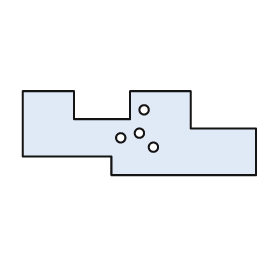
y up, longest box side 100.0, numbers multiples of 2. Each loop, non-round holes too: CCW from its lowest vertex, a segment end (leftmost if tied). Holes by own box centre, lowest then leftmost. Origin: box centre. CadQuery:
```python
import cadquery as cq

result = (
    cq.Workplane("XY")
    .moveTo(-12.0, -18.0)
    .lineTo(50.0, -18.0)
    .lineTo(50.0, 2.0)
    .lineTo(22.0, 2.0)
    .lineTo(22.0, 18.0)
    .lineTo(-4.0, 18.0)
    .lineTo(-4.0, 6.0)
    .lineTo(-28.0, 6.0)
    .lineTo(-28.0, 18.0)
    .lineTo(-50.0, 18.0)
    .lineTo(-50.0, -10.0)
    .lineTo(-12.0, -10.0)
    .close()
    .moveTo(6.0, -6.0)
    .circle(2.0)
    .moveTo(-8.0, -2.0)
    .circle(2.0)
    .moveTo(0.0, 0.0)
    .circle(2.0)
    .moveTo(2.0, 10.0)
    .circle(2.0)
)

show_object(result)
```